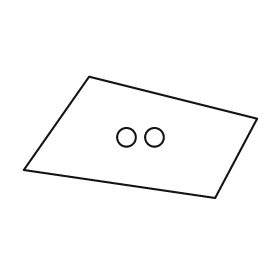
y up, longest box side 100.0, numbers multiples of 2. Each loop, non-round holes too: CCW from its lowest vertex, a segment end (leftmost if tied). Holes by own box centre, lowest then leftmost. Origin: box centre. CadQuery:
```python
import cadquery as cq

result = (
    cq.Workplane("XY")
    .moveTo(32.0, -26.0)
    .lineTo(50.0, 8.0)
    .lineTo(-22.0, 26.0)
    .lineTo(-50.0, -14.0)
    .close()
    .moveTo(-6.0, 0.0)
    .circle(4.0)
    .moveTo(6.0, 0.0)
    .circle(4.0)
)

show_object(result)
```